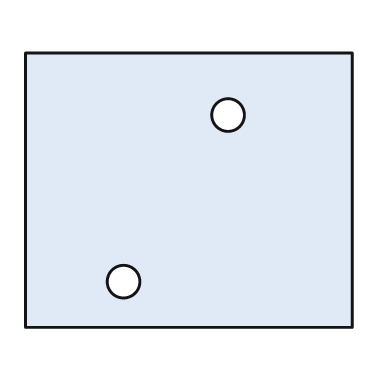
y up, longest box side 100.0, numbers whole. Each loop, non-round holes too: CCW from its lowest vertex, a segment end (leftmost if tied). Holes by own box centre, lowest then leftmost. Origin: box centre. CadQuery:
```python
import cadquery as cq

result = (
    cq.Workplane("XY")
    .moveTo(-50.0, -42.0)
    .lineTo(50.0, -42.0)
    .lineTo(50.0, 42.0)
    .lineTo(-50.0, 42.0)
    .close()
    .moveTo(-20.0, -28.0)
    .circle(5.0)
    .moveTo(12.0, 23.0)
    .circle(5.0)
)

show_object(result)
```